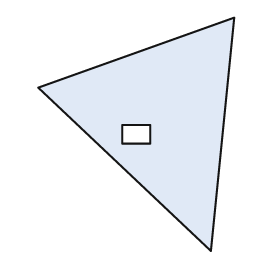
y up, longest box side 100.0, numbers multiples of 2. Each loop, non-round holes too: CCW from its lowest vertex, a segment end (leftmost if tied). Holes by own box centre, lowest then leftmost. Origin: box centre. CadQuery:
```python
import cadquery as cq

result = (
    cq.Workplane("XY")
    .moveTo(32.0, -50.0)
    .lineTo(42.0, 50.0)
    .lineTo(-42.0, 20.0)
    .close()
    .moveTo(-6.0, -4.0)
    .lineTo(6.0, -4.0)
    .lineTo(6.0, 4.0)
    .lineTo(-6.0, 4.0)
    .close()
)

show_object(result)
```